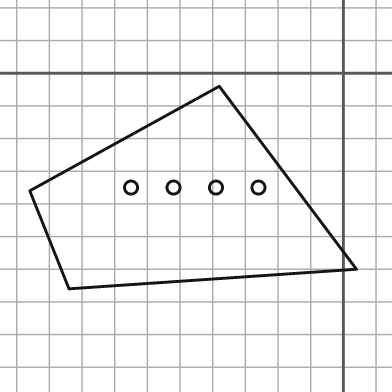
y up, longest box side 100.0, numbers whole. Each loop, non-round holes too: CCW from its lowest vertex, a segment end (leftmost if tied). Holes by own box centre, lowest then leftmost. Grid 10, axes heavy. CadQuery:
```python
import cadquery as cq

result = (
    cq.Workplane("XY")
    .moveTo(-84.0, -66.0)
    .lineTo(4.0, -60.0)
    .lineTo(-38.0, -4.0)
    .lineTo(-96.0, -36.0)
    .close()
    .moveTo(-65.0, -35.0)
    .circle(2.0)
    .moveTo(-52.0, -35.0)
    .circle(2.0)
    .moveTo(-39.0, -35.0)
    .circle(2.0)
    .moveTo(-26.0, -35.0)
    .circle(2.0)
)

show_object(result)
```